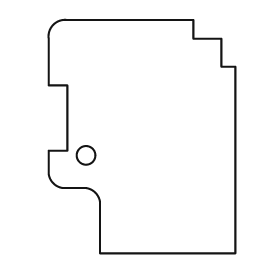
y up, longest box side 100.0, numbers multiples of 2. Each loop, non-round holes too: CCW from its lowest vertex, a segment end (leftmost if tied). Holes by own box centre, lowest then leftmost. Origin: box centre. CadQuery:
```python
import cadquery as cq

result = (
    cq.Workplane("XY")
    .moveTo(-18.0, -50.0)
    .lineTo(40.0, -50.0)
    .lineTo(40.0, 30.0)
    .lineTo(34.0, 30.0)
    .lineTo(34.0, 42.0)
    .lineTo(22.0, 42.0)
    .lineTo(22.0, 50.0)
    .lineTo(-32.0, 50.0)
    .threePointArc((-38.0, 48.0), (-40.0, 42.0))
    .lineTo(-40.0, 22.0)
    .lineTo(-32.0, 22.0)
    .lineTo(-32.0, -6.0)
    .lineTo(-40.0, -6.0)
    .lineTo(-40.0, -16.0)
    .threePointArc((-38.0, -20.0), (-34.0, -22.0))
    .lineTo(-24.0, -22.0)
    .threePointArc((-20.0, -24.0), (-18.0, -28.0))
    .close()
    .moveTo(-24.0, -8.0)
    .circle(4.0)
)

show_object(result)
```